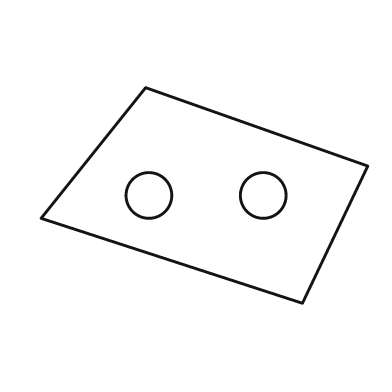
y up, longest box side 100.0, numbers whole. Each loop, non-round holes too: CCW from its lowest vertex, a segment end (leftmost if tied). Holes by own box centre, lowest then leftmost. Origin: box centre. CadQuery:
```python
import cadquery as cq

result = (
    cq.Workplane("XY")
    .moveTo(30.0, -33.0)
    .lineTo(50.0, 9.0)
    .lineTo(-18.0, 33.0)
    .lineTo(-50.0, -7.0)
    .close()
    .moveTo(-17.0, 0.0)
    .circle(7.0)
    .moveTo(18.0, 0.0)
    .circle(7.0)
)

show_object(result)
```